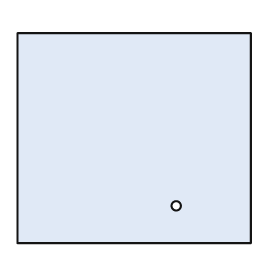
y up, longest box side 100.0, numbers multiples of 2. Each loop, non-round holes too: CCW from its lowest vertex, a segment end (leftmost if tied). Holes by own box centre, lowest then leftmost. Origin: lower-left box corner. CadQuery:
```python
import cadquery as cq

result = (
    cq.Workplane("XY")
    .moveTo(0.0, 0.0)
    .lineTo(100.0, 0.0)
    .lineTo(100.0, 90.0)
    .lineTo(0.0, 90.0)
    .close()
    .moveTo(68.0, 16.0)
    .circle(2.0)
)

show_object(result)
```